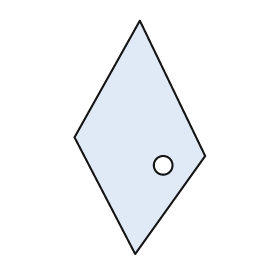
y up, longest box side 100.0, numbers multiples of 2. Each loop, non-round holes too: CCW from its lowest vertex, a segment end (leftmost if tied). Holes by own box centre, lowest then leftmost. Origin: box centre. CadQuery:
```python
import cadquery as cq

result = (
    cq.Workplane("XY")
    .moveTo(-2.0, -50.0)
    .lineTo(28.0, -8.0)
    .lineTo(0.0, 50.0)
    .lineTo(-28.0, 0.0)
    .close()
    .moveTo(10.0, -12.0)
    .circle(4.0)
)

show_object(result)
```